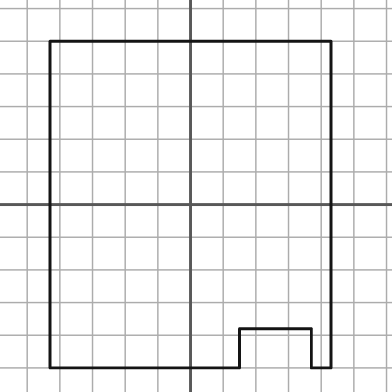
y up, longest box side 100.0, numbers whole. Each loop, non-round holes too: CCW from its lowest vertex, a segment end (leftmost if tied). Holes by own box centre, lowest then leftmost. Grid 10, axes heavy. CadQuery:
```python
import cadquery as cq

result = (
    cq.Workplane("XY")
    .moveTo(-43.0, -50.0)
    .lineTo(15.0, -50.0)
    .lineTo(15.0, -38.0)
    .lineTo(37.0, -38.0)
    .lineTo(37.0, -50.0)
    .lineTo(43.0, -50.0)
    .lineTo(43.0, 50.0)
    .lineTo(-43.0, 50.0)
    .close()
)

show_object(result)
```